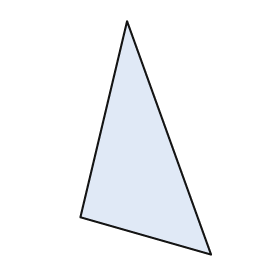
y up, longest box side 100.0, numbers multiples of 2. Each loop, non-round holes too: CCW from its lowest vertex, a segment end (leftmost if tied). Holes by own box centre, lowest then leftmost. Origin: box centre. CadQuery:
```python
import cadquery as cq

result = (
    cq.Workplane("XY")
    .moveTo(28.0, -50.0)
    .lineTo(-8.0, 50.0)
    .lineTo(-28.0, -34.0)
    .close()
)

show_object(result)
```